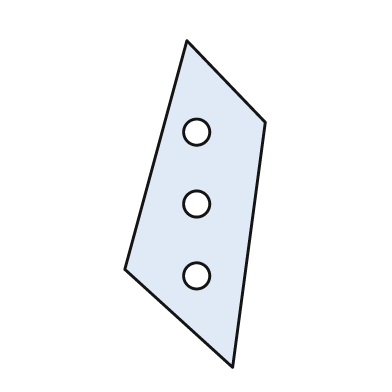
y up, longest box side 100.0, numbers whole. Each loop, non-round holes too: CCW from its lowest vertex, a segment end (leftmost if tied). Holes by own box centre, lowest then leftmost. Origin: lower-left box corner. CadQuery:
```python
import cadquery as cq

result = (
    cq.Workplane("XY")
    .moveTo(33.0, 0.0)
    .lineTo(43.0, 75.0)
    .lineTo(19.0, 100.0)
    .lineTo(0.0, 30.0)
    .close()
    .moveTo(22.0, 28.0)
    .circle(4.0)
    .moveTo(22.0, 50.0)
    .circle(4.0)
    .moveTo(22.0, 72.0)
    .circle(4.0)
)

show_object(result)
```